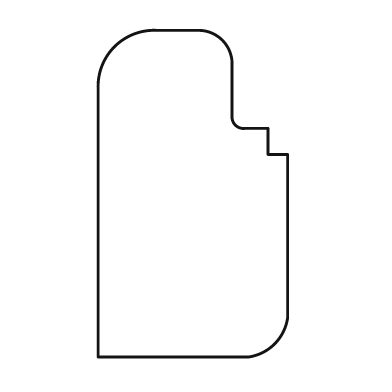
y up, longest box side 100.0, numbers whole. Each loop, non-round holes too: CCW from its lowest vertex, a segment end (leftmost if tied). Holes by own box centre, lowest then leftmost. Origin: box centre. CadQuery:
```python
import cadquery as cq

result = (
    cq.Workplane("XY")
    .moveTo(-29.0, -50.0)
    .lineTo(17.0, -50.0)
    .threePointArc((25.0, -46.0), (29.0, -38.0))
    .lineTo(29.0, 12.0)
    .lineTo(23.0, 12.0)
    .lineTo(23.0, 20.0)
    .lineTo(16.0, 20.0)
    .threePointArc((13.0, 21.0), (12.0, 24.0))
    .lineTo(12.0, 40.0)
    .threePointArc((9.0, 47.0), (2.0, 50.0))
    .lineTo(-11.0, 50.0)
    .threePointArc((-24.0, 45.0), (-29.0, 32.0))
    .close()
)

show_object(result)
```